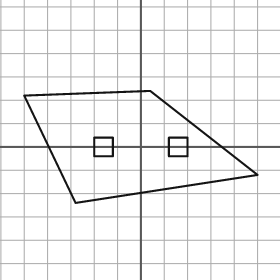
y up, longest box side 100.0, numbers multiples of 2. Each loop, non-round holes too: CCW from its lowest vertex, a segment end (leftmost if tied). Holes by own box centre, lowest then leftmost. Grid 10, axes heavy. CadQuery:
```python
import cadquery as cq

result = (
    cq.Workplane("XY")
    .moveTo(-28.0, -24.0)
    .lineTo(50.0, -12.0)
    .lineTo(4.0, 24.0)
    .lineTo(-50.0, 22.0)
    .close()
    .moveTo(-20.0, -4.0)
    .lineTo(-12.0, -4.0)
    .lineTo(-12.0, 4.0)
    .lineTo(-20.0, 4.0)
    .close()
    .moveTo(12.0, -4.0)
    .lineTo(20.0, -4.0)
    .lineTo(20.0, 4.0)
    .lineTo(12.0, 4.0)
    .close()
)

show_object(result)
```